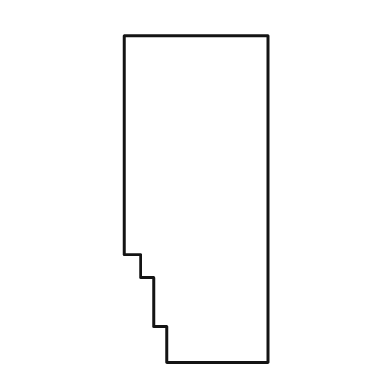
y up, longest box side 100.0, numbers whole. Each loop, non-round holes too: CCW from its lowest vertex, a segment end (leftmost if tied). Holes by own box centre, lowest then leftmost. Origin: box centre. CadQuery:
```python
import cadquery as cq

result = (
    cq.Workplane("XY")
    .moveTo(-9.0, -50.0)
    .lineTo(22.0, -50.0)
    .lineTo(22.0, 50.0)
    .lineTo(-22.0, 50.0)
    .lineTo(-22.0, -17.0)
    .lineTo(-17.0, -17.0)
    .lineTo(-17.0, -24.0)
    .lineTo(-13.0, -24.0)
    .lineTo(-13.0, -39.0)
    .lineTo(-9.0, -39.0)
    .close()
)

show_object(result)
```